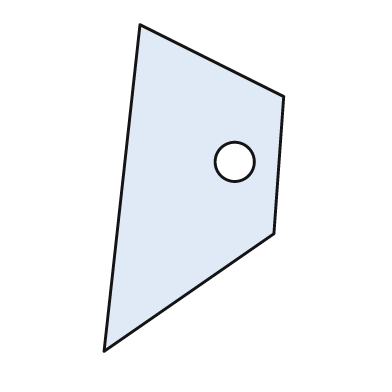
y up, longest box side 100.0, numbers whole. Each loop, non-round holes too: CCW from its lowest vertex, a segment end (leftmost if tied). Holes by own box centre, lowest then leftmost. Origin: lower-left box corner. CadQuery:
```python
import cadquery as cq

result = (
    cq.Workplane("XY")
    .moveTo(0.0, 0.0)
    .lineTo(52.0, 36.0)
    .lineTo(55.0, 78.0)
    .lineTo(11.0, 100.0)
    .close()
    .moveTo(40.0, 58.0)
    .circle(6.0)
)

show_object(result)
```